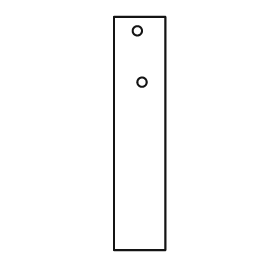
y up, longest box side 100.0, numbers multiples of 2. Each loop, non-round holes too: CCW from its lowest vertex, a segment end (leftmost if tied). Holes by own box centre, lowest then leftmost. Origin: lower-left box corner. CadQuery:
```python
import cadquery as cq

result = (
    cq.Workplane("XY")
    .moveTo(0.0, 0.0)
    .lineTo(22.0, 0.0)
    .lineTo(22.0, 100.0)
    .lineTo(0.0, 100.0)
    .close()
    .moveTo(12.0, 72.0)
    .circle(2.0)
    .moveTo(10.0, 94.0)
    .circle(2.0)
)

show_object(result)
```